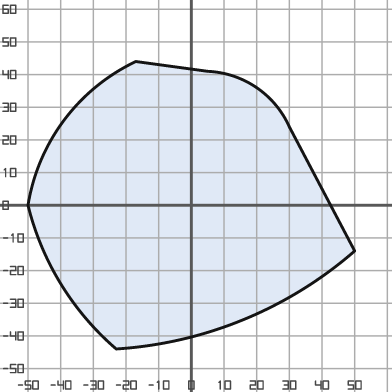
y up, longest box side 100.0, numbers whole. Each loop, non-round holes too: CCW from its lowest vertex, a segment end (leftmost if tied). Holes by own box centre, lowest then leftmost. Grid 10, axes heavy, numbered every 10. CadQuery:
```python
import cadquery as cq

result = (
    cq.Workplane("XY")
    .moveTo(-23.0, -44.0)
    .threePointArc((16.0, -35.0), (50.0, -14.0))
    .lineTo(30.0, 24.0)
    .threePointArc((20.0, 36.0), (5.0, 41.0))
    .lineTo(-17.0, 44.0)
    .threePointArc((-39.0, 26.0), (-50.0, 0.0))
    .threePointArc((-40.0, -24.0), (-23.0, -44.0))
    .close()
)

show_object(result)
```